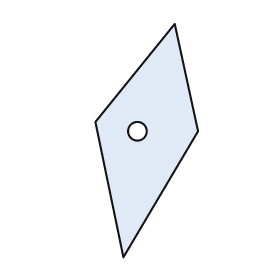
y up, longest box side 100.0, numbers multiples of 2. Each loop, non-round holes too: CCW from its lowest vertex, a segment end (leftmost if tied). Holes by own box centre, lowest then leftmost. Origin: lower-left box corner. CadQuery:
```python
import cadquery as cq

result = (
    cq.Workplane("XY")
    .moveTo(12.0, 0.0)
    .lineTo(44.0, 54.0)
    .lineTo(34.0, 100.0)
    .lineTo(0.0, 58.0)
    .close()
    .moveTo(18.0, 54.0)
    .circle(4.0)
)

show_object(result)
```